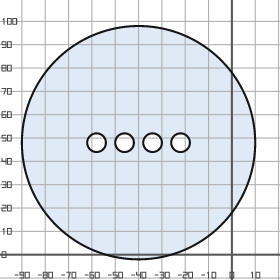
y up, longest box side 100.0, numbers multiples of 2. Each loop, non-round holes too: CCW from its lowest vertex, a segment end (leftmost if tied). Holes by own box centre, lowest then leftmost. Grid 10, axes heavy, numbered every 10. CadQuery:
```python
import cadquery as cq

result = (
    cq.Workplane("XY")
    .moveTo(-40.0, 48.0)
    .circle(50.0)
    .moveTo(-58.0, 48.0)
    .circle(4.0)
    .moveTo(-46.0, 48.0)
    .circle(4.0)
    .moveTo(-34.0, 48.0)
    .circle(4.0)
    .moveTo(-22.0, 48.0)
    .circle(4.0)
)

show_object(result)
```